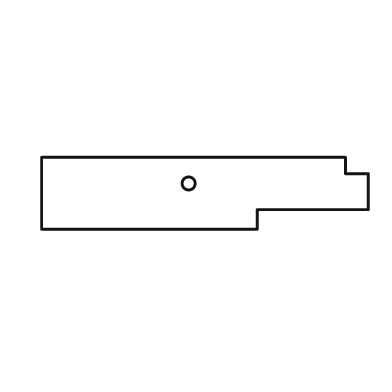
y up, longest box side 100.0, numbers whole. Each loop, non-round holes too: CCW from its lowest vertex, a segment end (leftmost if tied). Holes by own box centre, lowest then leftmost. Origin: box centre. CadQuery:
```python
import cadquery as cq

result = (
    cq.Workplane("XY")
    .moveTo(-50.0, -11.0)
    .lineTo(16.0, -11.0)
    .lineTo(16.0, -5.0)
    .lineTo(50.0, -5.0)
    .lineTo(50.0, 6.0)
    .lineTo(43.0, 6.0)
    .lineTo(43.0, 11.0)
    .lineTo(-50.0, 11.0)
    .close()
    .moveTo(-5.0, 3.0)
    .circle(2.0)
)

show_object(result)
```